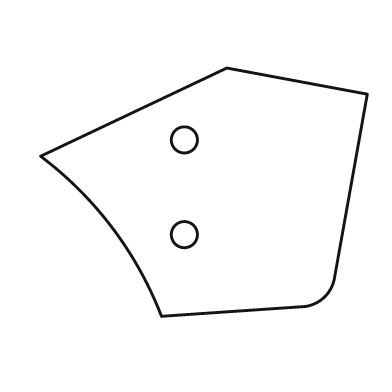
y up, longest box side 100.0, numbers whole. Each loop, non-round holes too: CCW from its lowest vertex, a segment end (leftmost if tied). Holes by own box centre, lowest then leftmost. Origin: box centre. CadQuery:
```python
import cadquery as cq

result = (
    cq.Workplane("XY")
    .moveTo(-13.0, -38.0)
    .lineTo(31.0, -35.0)
    .threePointArc((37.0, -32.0), (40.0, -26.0))
    .lineTo(50.0, 30.0)
    .lineTo(7.0, 38.0)
    .lineTo(-50.0, 11.0)
    .threePointArc((-28.0, -11.0), (-13.0, -38.0))
    .close()
    .moveTo(-6.0, -13.0)
    .circle(4.0)
    .moveTo(-6.0, 16.0)
    .circle(4.0)
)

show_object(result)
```